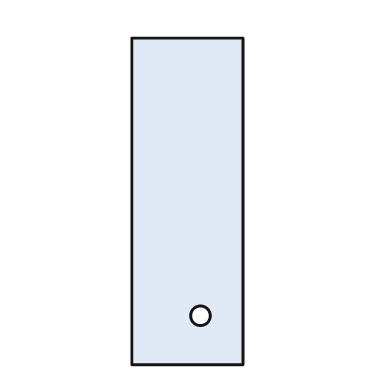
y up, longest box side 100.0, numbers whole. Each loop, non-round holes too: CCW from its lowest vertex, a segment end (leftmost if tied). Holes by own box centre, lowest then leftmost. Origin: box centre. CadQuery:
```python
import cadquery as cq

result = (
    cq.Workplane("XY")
    .moveTo(-17.0, -50.0)
    .lineTo(17.0, -50.0)
    .lineTo(17.0, 50.0)
    .lineTo(-17.0, 50.0)
    .close()
    .moveTo(4.0, -35.0)
    .circle(3.0)
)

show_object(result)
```